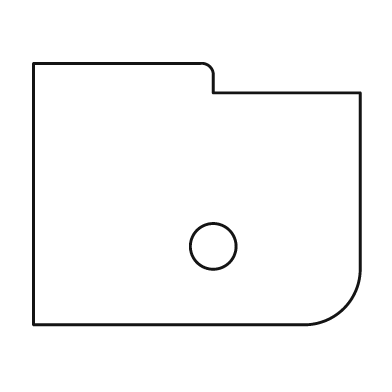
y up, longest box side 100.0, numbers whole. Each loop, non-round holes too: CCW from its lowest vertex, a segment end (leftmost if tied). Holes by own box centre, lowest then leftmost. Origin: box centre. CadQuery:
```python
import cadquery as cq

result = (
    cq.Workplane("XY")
    .moveTo(-50.0, -40.0)
    .lineTo(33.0, -40.0)
    .threePointArc((45.0, -35.0), (50.0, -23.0))
    .lineTo(50.0, 31.0)
    .lineTo(5.0, 31.0)
    .lineTo(5.0, 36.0)
    .threePointArc((4.0, 39.0), (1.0, 40.0))
    .lineTo(-50.0, 40.0)
    .close()
    .moveTo(5.0, -16.0)
    .circle(7.0)
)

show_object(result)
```